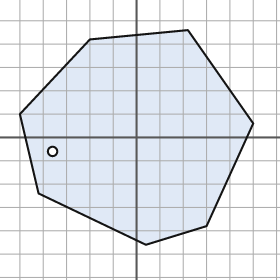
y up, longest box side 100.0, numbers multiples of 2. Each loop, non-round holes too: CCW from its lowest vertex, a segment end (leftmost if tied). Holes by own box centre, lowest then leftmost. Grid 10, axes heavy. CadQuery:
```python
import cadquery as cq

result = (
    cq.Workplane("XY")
    .moveTo(4.0, -46.0)
    .lineTo(30.0, -38.0)
    .lineTo(50.0, 6.0)
    .lineTo(22.0, 46.0)
    .lineTo(-20.0, 42.0)
    .lineTo(-50.0, 10.0)
    .lineTo(-42.0, -24.0)
    .close()
    .moveTo(-36.0, -6.0)
    .circle(2.0)
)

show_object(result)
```